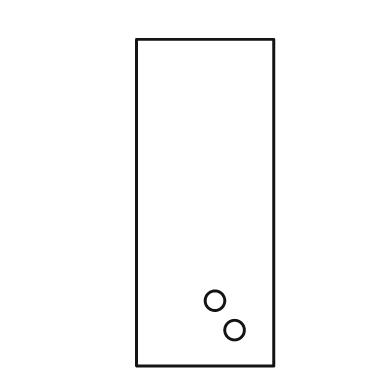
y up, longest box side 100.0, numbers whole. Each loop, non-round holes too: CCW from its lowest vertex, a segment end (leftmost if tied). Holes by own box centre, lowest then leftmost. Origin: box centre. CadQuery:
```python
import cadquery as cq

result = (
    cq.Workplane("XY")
    .moveTo(-21.0, -50.0)
    .lineTo(21.0, -50.0)
    .lineTo(21.0, 50.0)
    .lineTo(-21.0, 50.0)
    .close()
    .moveTo(9.0, -39.0)
    .circle(3.0)
    .moveTo(3.0, -30.0)
    .circle(3.0)
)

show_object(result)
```